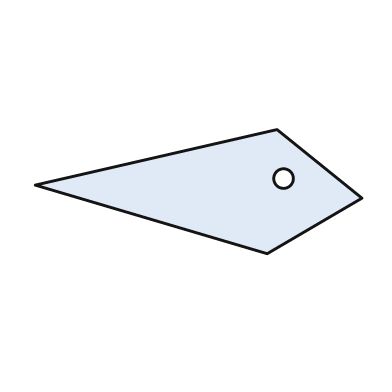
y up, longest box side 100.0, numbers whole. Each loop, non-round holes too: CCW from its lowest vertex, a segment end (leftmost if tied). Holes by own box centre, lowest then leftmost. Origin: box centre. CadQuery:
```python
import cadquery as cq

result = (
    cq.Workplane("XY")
    .moveTo(21.0, -19.0)
    .lineTo(50.0, -2.0)
    .lineTo(24.0, 19.0)
    .lineTo(-50.0, 2.0)
    .close()
    .moveTo(26.0, 4.0)
    .circle(3.0)
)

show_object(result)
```